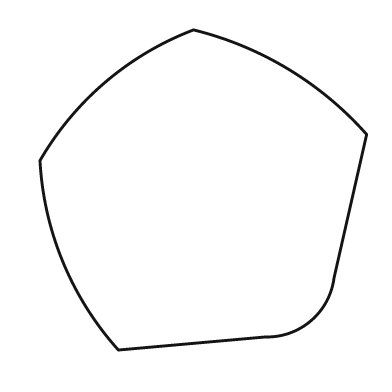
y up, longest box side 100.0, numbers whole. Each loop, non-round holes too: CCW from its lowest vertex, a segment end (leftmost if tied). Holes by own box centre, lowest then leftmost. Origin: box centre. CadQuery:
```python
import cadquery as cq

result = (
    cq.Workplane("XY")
    .moveTo(-26.0, -49.0)
    .lineTo(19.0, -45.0)
    .threePointArc((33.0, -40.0), (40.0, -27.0))
    .lineTo(50.0, 17.0)
    .threePointArc((26.0, 37.0), (-3.0, 49.0))
    .threePointArc((-30.0, 33.0), (-50.0, 9.0))
    .threePointArc((-43.0, -22.0), (-26.0, -49.0))
    .close()
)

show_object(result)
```